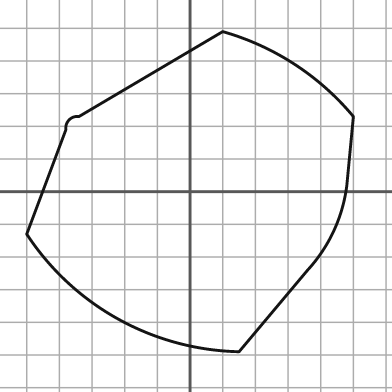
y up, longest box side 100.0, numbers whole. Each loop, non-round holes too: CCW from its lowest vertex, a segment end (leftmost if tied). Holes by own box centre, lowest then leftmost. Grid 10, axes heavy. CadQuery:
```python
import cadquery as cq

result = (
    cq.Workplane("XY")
    .moveTo(15.0, -49.0)
    .lineTo(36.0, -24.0)
    .threePointArc((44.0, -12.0), (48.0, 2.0))
    .lineTo(50.0, 23.0)
    .threePointArc((32.0, 39.0), (10.0, 49.0))
    .lineTo(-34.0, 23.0)
    .threePointArc((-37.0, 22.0), (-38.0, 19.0))
    .lineTo(-50.0, -13.0)
    .threePointArc((-22.0, -39.0), (15.0, -49.0))
    .close()
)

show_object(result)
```